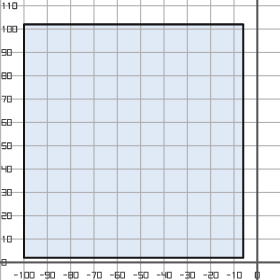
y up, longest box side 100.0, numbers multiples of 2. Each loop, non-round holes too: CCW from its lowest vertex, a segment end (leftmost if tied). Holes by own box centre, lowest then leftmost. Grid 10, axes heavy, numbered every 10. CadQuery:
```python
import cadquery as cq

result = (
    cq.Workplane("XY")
    .moveTo(-100.0, 2.0)
    .lineTo(-6.0, 2.0)
    .lineTo(-6.0, 102.0)
    .lineTo(-100.0, 102.0)
    .close()
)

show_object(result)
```